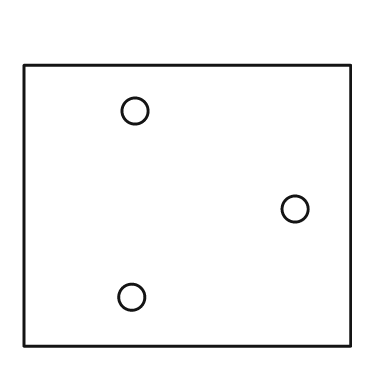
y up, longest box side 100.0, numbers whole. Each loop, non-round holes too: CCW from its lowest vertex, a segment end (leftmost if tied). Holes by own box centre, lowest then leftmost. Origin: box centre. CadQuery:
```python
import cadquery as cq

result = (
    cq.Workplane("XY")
    .moveTo(-50.0, -43.0)
    .lineTo(50.0, -43.0)
    .lineTo(50.0, 43.0)
    .lineTo(-50.0, 43.0)
    .close()
    .moveTo(-17.0, -28.0)
    .circle(4.0)
    .moveTo(33.0, -1.0)
    .circle(4.0)
    .moveTo(-16.0, 29.0)
    .circle(4.0)
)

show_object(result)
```